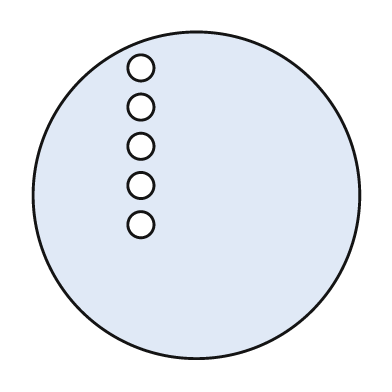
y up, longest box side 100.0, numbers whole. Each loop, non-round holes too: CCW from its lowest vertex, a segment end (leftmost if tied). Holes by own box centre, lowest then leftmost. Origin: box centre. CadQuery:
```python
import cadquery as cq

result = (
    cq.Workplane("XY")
    .moveTo(0.0, 0.0)
    .circle(50.0)
    .moveTo(-17.0, -9.0)
    .circle(4.0)
    .moveTo(-17.0, 3.0)
    .circle(4.0)
    .moveTo(-17.0, 15.0)
    .circle(4.0)
    .moveTo(-17.0, 27.0)
    .circle(4.0)
    .moveTo(-17.0, 39.0)
    .circle(4.0)
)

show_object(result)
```